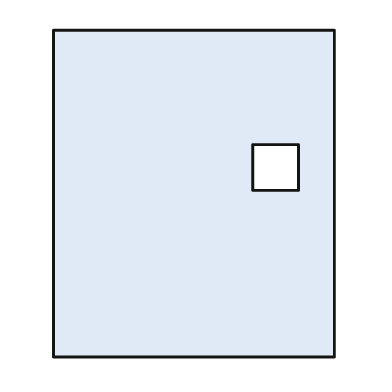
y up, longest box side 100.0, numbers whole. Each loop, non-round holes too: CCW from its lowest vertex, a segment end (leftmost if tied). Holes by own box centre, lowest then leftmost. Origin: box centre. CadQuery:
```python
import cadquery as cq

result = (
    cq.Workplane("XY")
    .moveTo(-43.0, -50.0)
    .lineTo(43.0, -50.0)
    .lineTo(43.0, 50.0)
    .lineTo(-43.0, 50.0)
    .close()
    .moveTo(18.0, 1.0)
    .lineTo(32.0, 1.0)
    .lineTo(32.0, 15.0)
    .lineTo(18.0, 15.0)
    .close()
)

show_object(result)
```